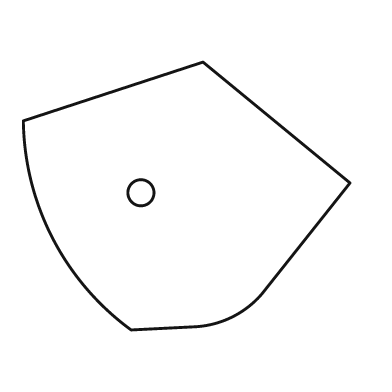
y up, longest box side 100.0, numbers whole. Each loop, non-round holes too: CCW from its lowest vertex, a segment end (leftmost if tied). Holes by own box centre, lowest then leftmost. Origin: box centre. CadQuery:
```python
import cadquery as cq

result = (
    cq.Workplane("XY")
    .moveTo(-17.0, -41.0)
    .lineTo(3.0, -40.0)
    .threePointArc((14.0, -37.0), (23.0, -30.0))
    .lineTo(50.0, 4.0)
    .lineTo(5.0, 41.0)
    .lineTo(-50.0, 23.0)
    .threePointArc((-41.0, -13.0), (-17.0, -41.0))
    .close()
    .moveTo(-14.0, 1.0)
    .circle(4.0)
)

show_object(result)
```